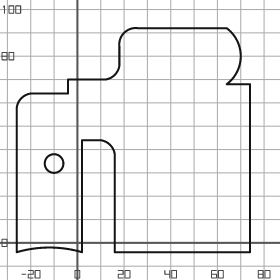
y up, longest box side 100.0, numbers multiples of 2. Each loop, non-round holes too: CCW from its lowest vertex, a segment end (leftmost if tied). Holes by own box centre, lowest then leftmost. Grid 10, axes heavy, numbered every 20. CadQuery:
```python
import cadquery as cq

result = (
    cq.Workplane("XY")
    .moveTo(-26.0, -4.0)
    .threePointArc((-12.0, -2.0), (2.0, -4.0))
    .lineTo(2.0, 44.0)
    .lineTo(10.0, 44.0)
    .threePointArc((14.0, 42.0), (16.0, 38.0))
    .lineTo(16.0, -4.0)
    .lineTo(74.0, -4.0)
    .lineTo(74.0, 68.0)
    .lineTo(64.0, 68.0)
    .threePointArc((70.0, 80.0), (64.0, 92.0))
    .lineTo(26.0, 92.0)
    .threePointArc((20.0, 90.0), (18.0, 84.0))
    .lineTo(18.0, 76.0)
    .threePointArc((16.0, 72.0), (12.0, 70.0))
    .lineTo(-4.0, 70.0)
    .lineTo(-4.0, 64.0)
    .lineTo(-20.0, 64.0)
    .threePointArc((-24.0, 62.0), (-26.0, 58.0))
    .close()
    .moveTo(-10.0, 34.0)
    .circle(4.0)
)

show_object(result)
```